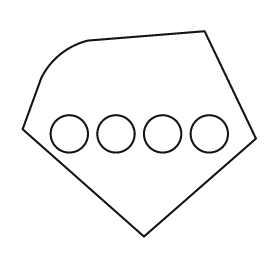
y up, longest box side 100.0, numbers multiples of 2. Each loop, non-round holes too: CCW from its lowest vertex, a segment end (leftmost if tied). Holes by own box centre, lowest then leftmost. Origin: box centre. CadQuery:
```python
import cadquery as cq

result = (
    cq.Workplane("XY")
    .moveTo(2.0, -44.0)
    .lineTo(50.0, -2.0)
    .lineTo(28.0, 44.0)
    .lineTo(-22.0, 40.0)
    .threePointArc((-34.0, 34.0), (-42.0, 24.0))
    .lineTo(-50.0, 2.0)
    .close()
    .moveTo(-30.0, 0.0)
    .circle(8.0)
    .moveTo(-10.0, 0.0)
    .circle(8.0)
    .moveTo(10.0, 0.0)
    .circle(8.0)
    .moveTo(30.0, 0.0)
    .circle(8.0)
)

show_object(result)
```